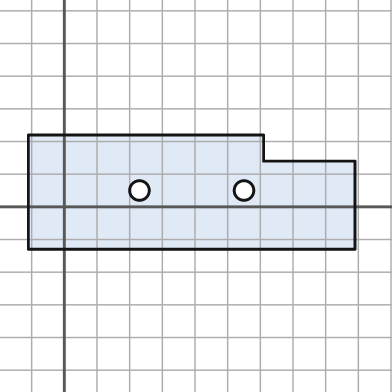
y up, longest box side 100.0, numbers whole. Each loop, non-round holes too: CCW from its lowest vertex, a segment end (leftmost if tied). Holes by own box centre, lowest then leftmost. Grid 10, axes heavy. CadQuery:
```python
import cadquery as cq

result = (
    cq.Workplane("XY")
    .moveTo(-11.0, -13.0)
    .lineTo(89.0, -13.0)
    .lineTo(89.0, 14.0)
    .lineTo(61.0, 14.0)
    .lineTo(61.0, 22.0)
    .lineTo(-11.0, 22.0)
    .close()
    .moveTo(23.0, 5.0)
    .circle(3.0)
    .moveTo(55.0, 5.0)
    .circle(3.0)
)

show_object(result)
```